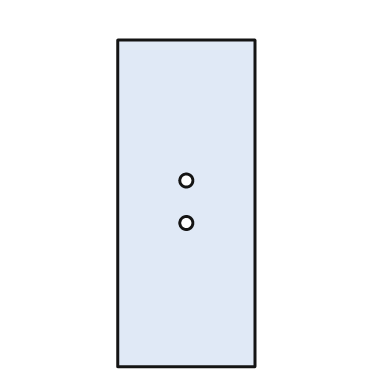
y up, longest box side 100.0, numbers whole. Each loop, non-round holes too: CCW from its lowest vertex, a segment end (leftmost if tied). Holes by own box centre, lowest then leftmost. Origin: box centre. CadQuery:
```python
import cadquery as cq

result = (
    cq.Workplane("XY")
    .moveTo(-21.0, -50.0)
    .lineTo(21.0, -50.0)
    .lineTo(21.0, 50.0)
    .lineTo(-21.0, 50.0)
    .close()
    .moveTo(0.0, -6.0)
    .circle(2.0)
    .moveTo(0.0, 7.0)
    .circle(2.0)
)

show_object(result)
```